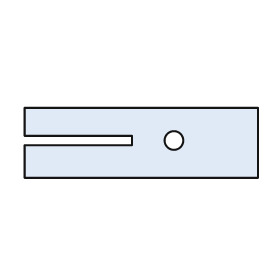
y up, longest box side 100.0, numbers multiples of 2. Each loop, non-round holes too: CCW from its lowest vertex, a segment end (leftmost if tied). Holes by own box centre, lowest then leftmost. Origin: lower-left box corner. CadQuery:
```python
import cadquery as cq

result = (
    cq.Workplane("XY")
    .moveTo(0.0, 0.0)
    .lineTo(100.0, 0.0)
    .lineTo(100.0, 30.0)
    .lineTo(0.0, 30.0)
    .lineTo(0.0, 18.0)
    .lineTo(46.0, 18.0)
    .lineTo(46.0, 14.0)
    .lineTo(0.0, 14.0)
    .close()
    .moveTo(64.0, 16.0)
    .circle(4.0)
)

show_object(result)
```